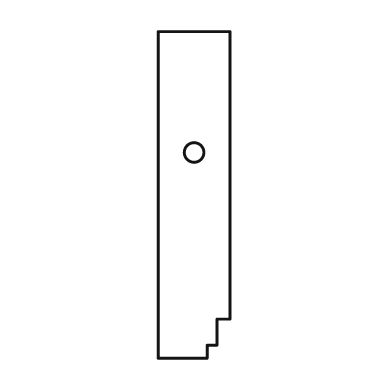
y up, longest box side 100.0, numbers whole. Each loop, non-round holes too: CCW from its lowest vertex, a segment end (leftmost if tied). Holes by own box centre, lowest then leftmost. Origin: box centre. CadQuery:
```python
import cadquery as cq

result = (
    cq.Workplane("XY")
    .moveTo(-11.0, -50.0)
    .lineTo(4.0, -50.0)
    .lineTo(4.0, -46.0)
    .lineTo(7.0, -46.0)
    .lineTo(7.0, -38.0)
    .lineTo(11.0, -38.0)
    .lineTo(11.0, 50.0)
    .lineTo(-11.0, 50.0)
    .close()
    .moveTo(0.0, 13.0)
    .circle(3.0)
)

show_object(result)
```